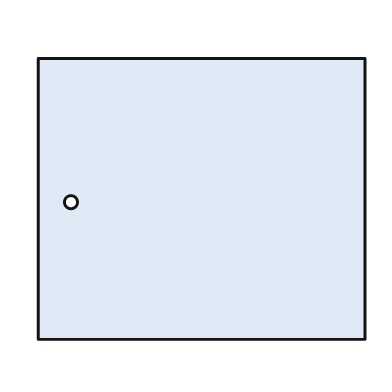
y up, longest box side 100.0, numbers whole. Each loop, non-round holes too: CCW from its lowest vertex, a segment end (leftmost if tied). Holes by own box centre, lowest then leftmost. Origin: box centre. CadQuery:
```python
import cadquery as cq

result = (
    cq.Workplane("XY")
    .moveTo(-50.0, -43.0)
    .lineTo(50.0, -43.0)
    .lineTo(50.0, 43.0)
    .lineTo(-50.0, 43.0)
    .close()
    .moveTo(-40.0, -1.0)
    .circle(2.0)
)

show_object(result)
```